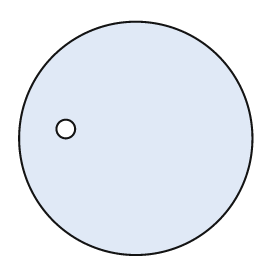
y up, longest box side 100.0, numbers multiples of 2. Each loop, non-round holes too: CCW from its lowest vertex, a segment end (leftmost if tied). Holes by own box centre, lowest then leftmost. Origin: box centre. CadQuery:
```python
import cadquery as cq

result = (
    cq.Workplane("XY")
    .moveTo(0.0, 0.0)
    .circle(50.0)
    .moveTo(-30.0, 4.0)
    .circle(4.0)
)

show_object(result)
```